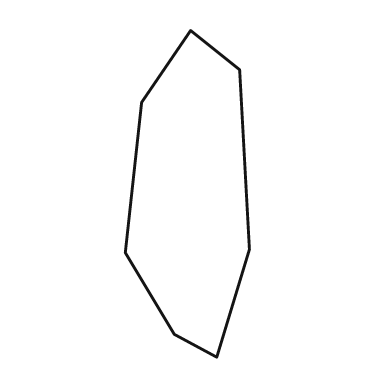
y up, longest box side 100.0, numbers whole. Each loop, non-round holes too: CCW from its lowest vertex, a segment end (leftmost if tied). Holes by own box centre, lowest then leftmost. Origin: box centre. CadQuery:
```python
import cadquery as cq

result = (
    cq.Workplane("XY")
    .moveTo(9.0, -50.0)
    .lineTo(19.0, -17.0)
    .lineTo(16.0, 38.0)
    .lineTo(1.0, 50.0)
    .lineTo(-14.0, 28.0)
    .lineTo(-19.0, -18.0)
    .lineTo(-4.0, -43.0)
    .close()
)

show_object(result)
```